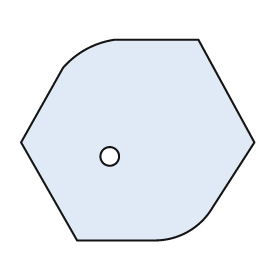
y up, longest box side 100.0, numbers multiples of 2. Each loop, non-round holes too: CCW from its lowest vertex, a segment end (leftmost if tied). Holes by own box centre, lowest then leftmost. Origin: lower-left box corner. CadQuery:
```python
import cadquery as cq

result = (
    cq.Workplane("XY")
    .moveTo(24.0, 0.0)
    .lineTo(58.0, 0.0)
    .threePointArc((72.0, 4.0), (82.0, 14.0))
    .lineTo(100.0, 42.0)
    .lineTo(76.0, 86.0)
    .lineTo(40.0, 86.0)
    .threePointArc((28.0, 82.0), (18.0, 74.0))
    .lineTo(0.0, 42.0)
    .close()
    .moveTo(38.0, 36.0)
    .circle(4.0)
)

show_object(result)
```